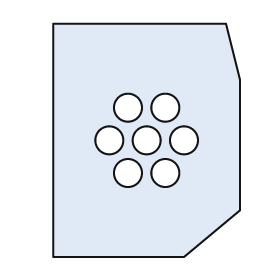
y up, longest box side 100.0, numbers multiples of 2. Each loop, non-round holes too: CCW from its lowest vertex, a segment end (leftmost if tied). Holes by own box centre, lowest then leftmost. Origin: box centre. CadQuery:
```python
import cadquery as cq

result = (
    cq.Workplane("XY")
    .moveTo(-40.0, -50.0)
    .lineTo(16.0, -50.0)
    .lineTo(40.0, -30.0)
    .lineTo(40.0, 26.0)
    .lineTo(34.0, 50.0)
    .lineTo(-40.0, 50.0)
    .close()
    .moveTo(-8.0, -14.0)
    .circle(6.0)
    .moveTo(8.0, -14.0)
    .circle(6.0)
    .moveTo(-16.0, 0.0)
    .circle(6.0)
    .moveTo(0.0, 0.0)
    .circle(6.0)
    .moveTo(16.0, 0.0)
    .circle(6.0)
    .moveTo(-8.0, 14.0)
    .circle(6.0)
    .moveTo(8.0, 14.0)
    .circle(6.0)
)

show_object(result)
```